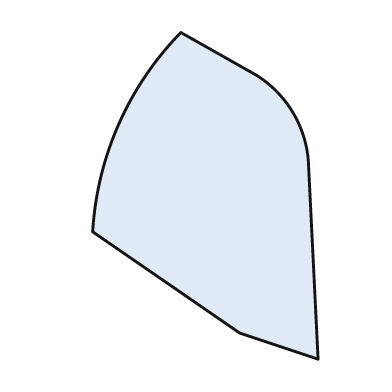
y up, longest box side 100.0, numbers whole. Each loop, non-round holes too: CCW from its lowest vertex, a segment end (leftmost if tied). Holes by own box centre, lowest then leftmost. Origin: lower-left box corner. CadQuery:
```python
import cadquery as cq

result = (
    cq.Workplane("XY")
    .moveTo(69.0, 0.0)
    .lineTo(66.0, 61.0)
    .threePointArc((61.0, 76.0), (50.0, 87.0))
    .lineTo(27.0, 100.0)
    .threePointArc((8.0, 72.0), (0.0, 39.0))
    .lineTo(45.0, 8.0)
    .close()
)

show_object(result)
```